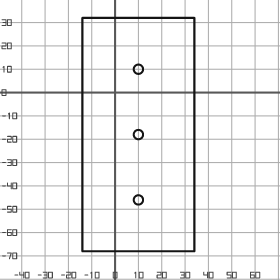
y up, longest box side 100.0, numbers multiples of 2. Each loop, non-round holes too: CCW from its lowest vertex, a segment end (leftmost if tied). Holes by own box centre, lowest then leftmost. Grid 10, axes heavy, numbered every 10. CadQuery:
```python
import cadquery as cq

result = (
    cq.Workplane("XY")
    .moveTo(-14.0, -68.0)
    .lineTo(34.0, -68.0)
    .lineTo(34.0, 32.0)
    .lineTo(-14.0, 32.0)
    .close()
    .moveTo(10.0, -46.0)
    .circle(2.0)
    .moveTo(10.0, -18.0)
    .circle(2.0)
    .moveTo(10.0, 10.0)
    .circle(2.0)
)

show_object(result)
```